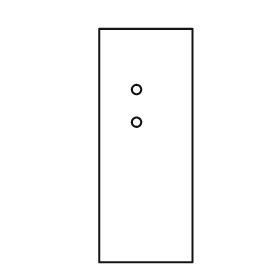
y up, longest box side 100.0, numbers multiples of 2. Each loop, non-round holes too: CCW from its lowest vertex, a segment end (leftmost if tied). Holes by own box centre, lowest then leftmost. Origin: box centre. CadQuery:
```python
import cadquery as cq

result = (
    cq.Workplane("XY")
    .moveTo(-20.0, -50.0)
    .lineTo(20.0, -50.0)
    .lineTo(20.0, 50.0)
    .lineTo(-20.0, 50.0)
    .close()
    .moveTo(-4.0, 10.0)
    .circle(2.0)
    .moveTo(-4.0, 24.0)
    .circle(2.0)
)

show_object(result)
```